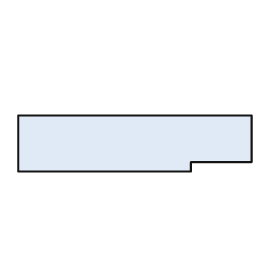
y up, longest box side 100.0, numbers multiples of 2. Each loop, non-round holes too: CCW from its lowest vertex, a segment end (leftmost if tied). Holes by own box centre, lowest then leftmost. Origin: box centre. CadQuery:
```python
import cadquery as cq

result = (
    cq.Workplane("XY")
    .moveTo(-50.0, -12.0)
    .lineTo(24.0, -12.0)
    .lineTo(24.0, -8.0)
    .lineTo(50.0, -8.0)
    .lineTo(50.0, 12.0)
    .lineTo(-50.0, 12.0)
    .close()
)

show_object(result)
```